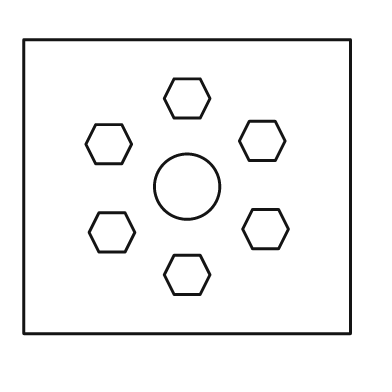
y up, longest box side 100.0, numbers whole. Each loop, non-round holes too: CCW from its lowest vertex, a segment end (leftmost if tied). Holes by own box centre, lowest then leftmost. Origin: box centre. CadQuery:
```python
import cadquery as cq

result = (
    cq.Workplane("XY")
    .moveTo(-50.0, -45.0)
    .lineTo(50.0, -45.0)
    .lineTo(50.0, 45.0)
    .lineTo(-50.0, 45.0)
    .close()
    .moveTo(-4.0, -33.0)
    .lineTo(4.0, -33.0)
    .lineTo(7.0, -27.0)
    .lineTo(4.0, -21.0)
    .lineTo(-4.0, -21.0)
    .lineTo(-7.0, -27.0)
    .close()
    .moveTo(-27.0, -20.0)
    .lineTo(-19.0, -20.0)
    .lineTo(-16.0, -14.0)
    .lineTo(-19.0, -8.0)
    .lineTo(-27.0, -8.0)
    .lineTo(-30.0, -14.0)
    .close()
    .moveTo(20.0, -19.0)
    .lineTo(28.0, -19.0)
    .lineTo(31.0, -13.0)
    .lineTo(28.0, -7.0)
    .lineTo(20.0, -7.0)
    .lineTo(17.0, -13.0)
    .close()
    .moveTo(0.0, 0.0)
    .circle(10.0)
    .moveTo(-28.0, 7.0)
    .lineTo(-20.0, 7.0)
    .lineTo(-17.0, 13.0)
    .lineTo(-20.0, 19.0)
    .lineTo(-28.0, 19.0)
    .lineTo(-31.0, 13.0)
    .close()
    .moveTo(19.0, 8.0)
    .lineTo(27.0, 8.0)
    .lineTo(30.0, 14.0)
    .lineTo(27.0, 20.0)
    .lineTo(19.0, 20.0)
    .lineTo(16.0, 14.0)
    .close()
    .moveTo(-4.0, 21.0)
    .lineTo(4.0, 21.0)
    .lineTo(7.0, 27.0)
    .lineTo(4.0, 33.0)
    .lineTo(-4.0, 33.0)
    .lineTo(-7.0, 27.0)
    .close()
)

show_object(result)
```